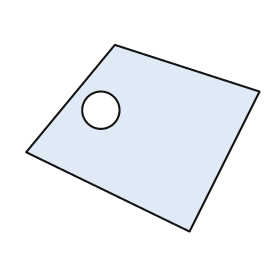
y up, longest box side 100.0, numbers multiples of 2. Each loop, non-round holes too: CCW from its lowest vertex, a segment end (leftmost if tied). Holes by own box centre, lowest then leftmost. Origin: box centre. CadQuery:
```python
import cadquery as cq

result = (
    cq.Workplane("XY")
    .moveTo(20.0, -40.0)
    .lineTo(50.0, 20.0)
    .lineTo(-12.0, 40.0)
    .lineTo(-50.0, -6.0)
    .close()
    .moveTo(-18.0, 12.0)
    .circle(8.0)
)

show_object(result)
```